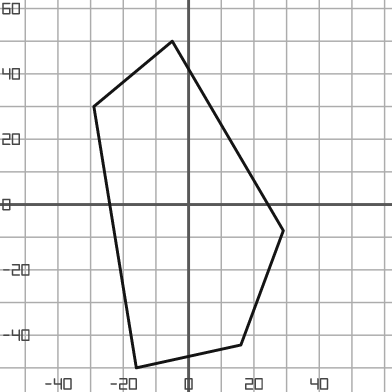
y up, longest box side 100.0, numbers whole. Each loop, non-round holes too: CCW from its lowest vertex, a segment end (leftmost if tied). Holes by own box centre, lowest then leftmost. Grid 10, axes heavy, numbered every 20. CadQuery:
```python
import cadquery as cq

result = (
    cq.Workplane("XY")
    .moveTo(-16.0, -50.0)
    .lineTo(16.0, -43.0)
    .lineTo(29.0, -8.0)
    .lineTo(-5.0, 50.0)
    .lineTo(-29.0, 30.0)
    .close()
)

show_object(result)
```